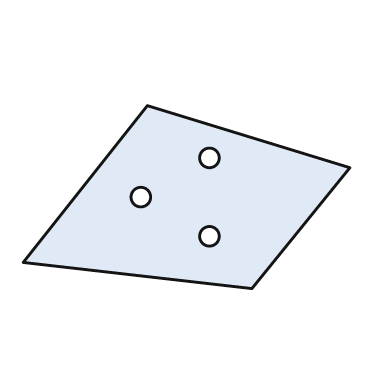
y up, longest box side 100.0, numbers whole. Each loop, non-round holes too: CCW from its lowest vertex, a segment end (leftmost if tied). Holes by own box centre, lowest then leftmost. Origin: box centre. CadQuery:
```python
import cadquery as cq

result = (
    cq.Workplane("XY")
    .moveTo(20.0, -28.0)
    .lineTo(50.0, 9.0)
    .lineTo(-12.0, 28.0)
    .lineTo(-50.0, -20.0)
    .close()
    .moveTo(7.0, -12.0)
    .circle(3.0)
    .moveTo(-14.0, 0.0)
    .circle(3.0)
    .moveTo(7.0, 12.0)
    .circle(3.0)
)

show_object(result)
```